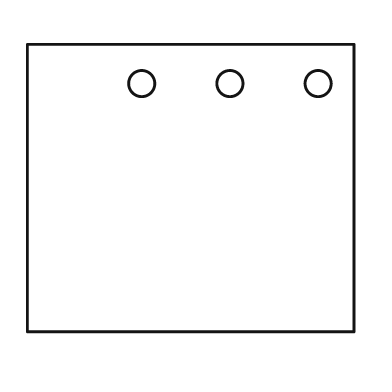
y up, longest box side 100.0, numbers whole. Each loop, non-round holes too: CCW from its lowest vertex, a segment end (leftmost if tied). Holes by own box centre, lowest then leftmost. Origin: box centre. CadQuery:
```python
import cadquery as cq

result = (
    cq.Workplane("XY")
    .moveTo(-50.0, -44.0)
    .lineTo(50.0, -44.0)
    .lineTo(50.0, 44.0)
    .lineTo(-50.0, 44.0)
    .close()
    .moveTo(-15.0, 32.0)
    .circle(4.0)
    .moveTo(12.0, 32.0)
    .circle(4.0)
    .moveTo(39.0, 32.0)
    .circle(4.0)
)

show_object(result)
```